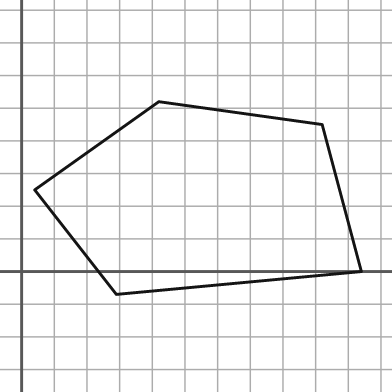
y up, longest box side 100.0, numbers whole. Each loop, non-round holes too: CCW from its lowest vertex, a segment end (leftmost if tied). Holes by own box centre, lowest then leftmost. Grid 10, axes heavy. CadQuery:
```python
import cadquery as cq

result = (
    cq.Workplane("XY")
    .moveTo(29.0, -7.0)
    .lineTo(104.0, 0.0)
    .lineTo(92.0, 45.0)
    .lineTo(42.0, 52.0)
    .lineTo(4.0, 25.0)
    .close()
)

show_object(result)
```